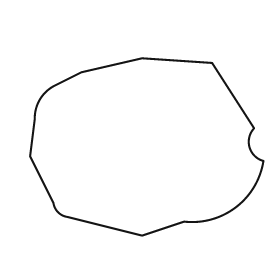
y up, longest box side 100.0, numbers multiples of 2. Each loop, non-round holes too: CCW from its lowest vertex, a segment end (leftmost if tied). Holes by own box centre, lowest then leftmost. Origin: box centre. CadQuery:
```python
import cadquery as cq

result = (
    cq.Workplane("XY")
    .moveTo(-2.0, -38.0)
    .lineTo(16.0, -32.0)
    .threePointArc((38.0, -26.0), (50.0, -6.0))
    .threePointArc((44.0, 0.0), (46.0, 8.0))
    .lineTo(28.0, 36.0)
    .lineTo(-2.0, 38.0)
    .lineTo(-28.0, 32.0)
    .lineTo(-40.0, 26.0)
    .threePointArc((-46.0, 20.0), (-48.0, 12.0))
    .lineTo(-50.0, -4.0)
    .lineTo(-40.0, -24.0)
    .threePointArc((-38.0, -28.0), (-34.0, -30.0))
    .close()
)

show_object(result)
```